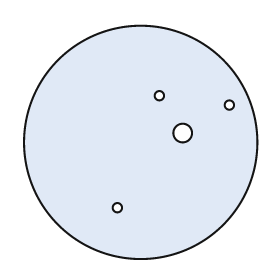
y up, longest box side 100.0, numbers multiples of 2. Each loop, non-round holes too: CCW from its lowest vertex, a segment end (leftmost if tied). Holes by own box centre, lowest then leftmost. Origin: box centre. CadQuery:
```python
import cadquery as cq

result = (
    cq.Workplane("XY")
    .moveTo(0.0, 0.0)
    .circle(50.0)
    .moveTo(-10.0, -28.0)
    .circle(2.0)
    .moveTo(18.0, 4.0)
    .circle(4.0)
    .moveTo(38.0, 16.0)
    .circle(2.0)
    .moveTo(8.0, 20.0)
    .circle(2.0)
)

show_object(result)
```